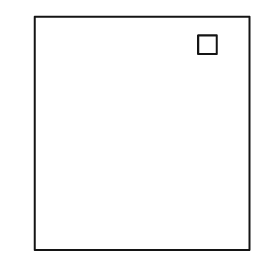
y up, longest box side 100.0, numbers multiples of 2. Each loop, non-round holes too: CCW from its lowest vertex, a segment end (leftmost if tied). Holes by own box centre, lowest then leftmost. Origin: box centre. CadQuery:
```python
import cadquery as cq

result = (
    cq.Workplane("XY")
    .moveTo(-46.0, -50.0)
    .lineTo(46.0, -50.0)
    .lineTo(46.0, 50.0)
    .lineTo(-46.0, 50.0)
    .close()
    .moveTo(24.0, 34.0)
    .lineTo(32.0, 34.0)
    .lineTo(32.0, 42.0)
    .lineTo(24.0, 42.0)
    .close()
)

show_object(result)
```